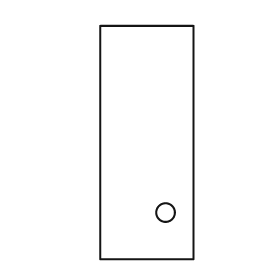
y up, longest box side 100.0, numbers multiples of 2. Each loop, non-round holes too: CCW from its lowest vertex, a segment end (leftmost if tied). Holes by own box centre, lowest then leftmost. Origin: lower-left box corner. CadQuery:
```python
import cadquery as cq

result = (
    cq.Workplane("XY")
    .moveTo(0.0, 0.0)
    .lineTo(40.0, 0.0)
    .lineTo(40.0, 100.0)
    .lineTo(0.0, 100.0)
    .close()
    .moveTo(28.0, 20.0)
    .circle(4.0)
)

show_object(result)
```